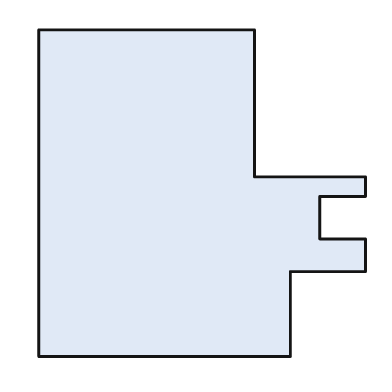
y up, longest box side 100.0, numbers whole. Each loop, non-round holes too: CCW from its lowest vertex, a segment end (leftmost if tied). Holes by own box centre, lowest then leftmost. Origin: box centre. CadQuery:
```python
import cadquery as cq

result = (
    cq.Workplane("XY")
    .moveTo(-50.0, -50.0)
    .lineTo(27.0, -50.0)
    .lineTo(27.0, -24.0)
    .lineTo(50.0, -24.0)
    .lineTo(50.0, -14.0)
    .lineTo(36.0, -14.0)
    .lineTo(36.0, -1.0)
    .lineTo(50.0, -1.0)
    .lineTo(50.0, 5.0)
    .lineTo(16.0, 5.0)
    .lineTo(16.0, 50.0)
    .lineTo(-50.0, 50.0)
    .close()
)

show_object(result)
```